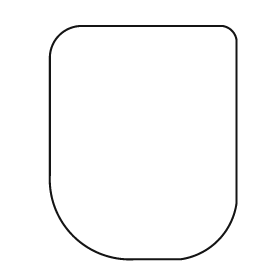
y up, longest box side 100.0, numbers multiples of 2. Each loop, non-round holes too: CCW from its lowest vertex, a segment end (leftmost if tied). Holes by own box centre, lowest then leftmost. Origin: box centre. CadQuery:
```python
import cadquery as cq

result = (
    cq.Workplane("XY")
    .moveTo(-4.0, -50.0)
    .lineTo(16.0, -50.0)
    .threePointArc((32.0, -42.0), (40.0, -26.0))
    .lineTo(40.0, 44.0)
    .threePointArc((38.0, 48.0), (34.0, 50.0))
    .lineTo(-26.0, 50.0)
    .threePointArc((-36.0, 46.0), (-40.0, 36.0))
    .lineTo(-40.0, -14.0)
    .threePointArc((-30.0, -40.0), (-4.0, -50.0))
    .close()
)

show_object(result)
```